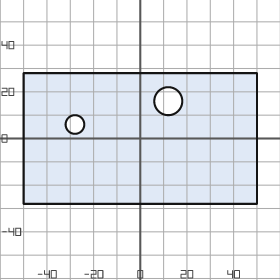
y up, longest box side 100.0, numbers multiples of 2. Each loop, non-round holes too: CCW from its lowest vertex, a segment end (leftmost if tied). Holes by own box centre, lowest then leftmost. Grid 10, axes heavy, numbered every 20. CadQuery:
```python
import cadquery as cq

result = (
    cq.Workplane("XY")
    .moveTo(-50.0, -28.0)
    .lineTo(50.0, -28.0)
    .lineTo(50.0, 28.0)
    .lineTo(-50.0, 28.0)
    .close()
    .moveTo(-28.0, 6.0)
    .circle(4.0)
    .moveTo(12.0, 16.0)
    .circle(6.0)
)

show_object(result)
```